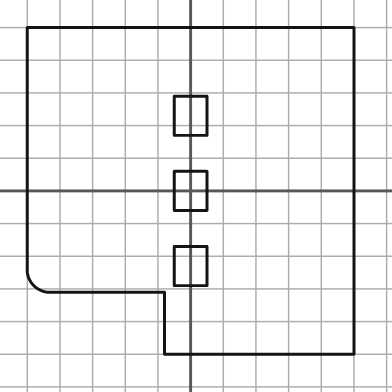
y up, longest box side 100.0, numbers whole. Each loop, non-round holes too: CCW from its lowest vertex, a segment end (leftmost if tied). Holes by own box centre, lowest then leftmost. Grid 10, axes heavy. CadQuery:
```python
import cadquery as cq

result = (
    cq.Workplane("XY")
    .moveTo(-8.0, -50.0)
    .lineTo(50.0, -50.0)
    .lineTo(50.0, 50.0)
    .lineTo(-50.0, 50.0)
    .lineTo(-50.0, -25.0)
    .threePointArc((-48.0, -29.0), (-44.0, -31.0))
    .lineTo(-8.0, -31.0)
    .close()
    .moveTo(-5.0, -29.0)
    .lineTo(5.0, -29.0)
    .lineTo(5.0, -17.0)
    .lineTo(-5.0, -17.0)
    .close()
    .moveTo(-5.0, -6.0)
    .lineTo(5.0, -6.0)
    .lineTo(5.0, 6.0)
    .lineTo(-5.0, 6.0)
    .close()
    .moveTo(-5.0, 17.0)
    .lineTo(5.0, 17.0)
    .lineTo(5.0, 29.0)
    .lineTo(-5.0, 29.0)
    .close()
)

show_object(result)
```